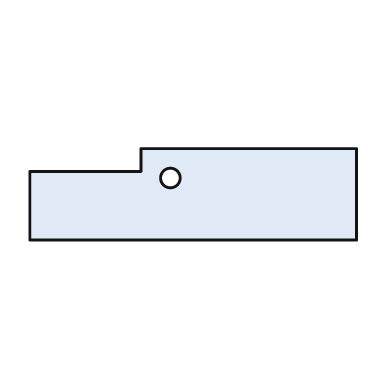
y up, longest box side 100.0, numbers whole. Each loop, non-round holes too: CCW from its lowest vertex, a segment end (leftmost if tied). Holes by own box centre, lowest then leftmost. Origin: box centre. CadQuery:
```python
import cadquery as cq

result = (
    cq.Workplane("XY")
    .moveTo(-50.0, -14.0)
    .lineTo(50.0, -14.0)
    .lineTo(50.0, 14.0)
    .lineTo(-16.0, 14.0)
    .lineTo(-16.0, 7.0)
    .lineTo(-50.0, 7.0)
    .close()
    .moveTo(-7.0, 5.0)
    .circle(3.0)
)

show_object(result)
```